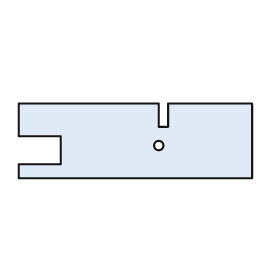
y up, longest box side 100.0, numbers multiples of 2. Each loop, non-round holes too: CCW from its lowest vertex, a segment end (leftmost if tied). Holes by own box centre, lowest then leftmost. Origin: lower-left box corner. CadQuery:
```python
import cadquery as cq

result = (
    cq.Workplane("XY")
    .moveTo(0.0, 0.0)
    .lineTo(100.0, 0.0)
    .lineTo(100.0, 32.0)
    .lineTo(64.0, 32.0)
    .lineTo(64.0, 22.0)
    .lineTo(60.0, 22.0)
    .lineTo(60.0, 32.0)
    .lineTo(0.0, 32.0)
    .lineTo(0.0, 18.0)
    .lineTo(18.0, 18.0)
    .lineTo(18.0, 6.0)
    .lineTo(0.0, 6.0)
    .close()
    .moveTo(60.0, 14.0)
    .circle(2.0)
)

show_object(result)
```